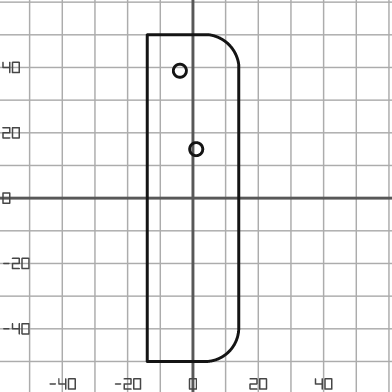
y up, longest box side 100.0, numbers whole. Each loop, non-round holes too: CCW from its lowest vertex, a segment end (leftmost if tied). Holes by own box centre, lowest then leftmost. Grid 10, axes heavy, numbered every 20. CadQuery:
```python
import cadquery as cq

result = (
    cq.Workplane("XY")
    .moveTo(-14.0, -50.0)
    .lineTo(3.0, -50.0)
    .threePointArc((11.0, -47.0), (14.0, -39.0))
    .lineTo(14.0, 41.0)
    .threePointArc((11.0, 47.0), (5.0, 50.0))
    .lineTo(-14.0, 50.0)
    .close()
    .moveTo(1.0, 15.0)
    .circle(2.0)
    .moveTo(-4.0, 39.0)
    .circle(2.0)
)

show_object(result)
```